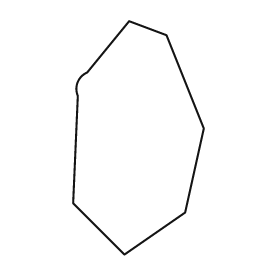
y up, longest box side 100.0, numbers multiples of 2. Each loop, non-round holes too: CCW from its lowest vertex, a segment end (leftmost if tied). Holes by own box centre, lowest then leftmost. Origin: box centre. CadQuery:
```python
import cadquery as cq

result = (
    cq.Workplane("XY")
    .moveTo(-6.0, -50.0)
    .lineTo(20.0, -32.0)
    .lineTo(28.0, 4.0)
    .lineTo(12.0, 44.0)
    .lineTo(-4.0, 50.0)
    .lineTo(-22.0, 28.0)
    .threePointArc((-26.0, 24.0), (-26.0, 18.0))
    .lineTo(-28.0, -28.0)
    .close()
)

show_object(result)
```